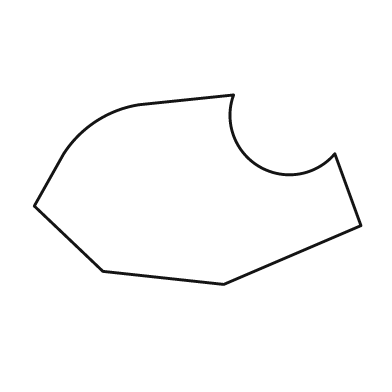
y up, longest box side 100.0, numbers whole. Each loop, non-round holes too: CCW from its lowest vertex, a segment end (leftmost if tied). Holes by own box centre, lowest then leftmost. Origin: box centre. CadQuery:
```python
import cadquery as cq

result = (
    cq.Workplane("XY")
    .moveTo(8.0, -29.0)
    .lineTo(50.0, -11.0)
    .lineTo(42.0, 11.0)
    .threePointArc((19.0, 7.0), (11.0, 29.0))
    .lineTo(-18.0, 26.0)
    .threePointArc((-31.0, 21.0), (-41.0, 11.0))
    .lineTo(-50.0, -5.0)
    .lineTo(-29.0, -25.0)
    .close()
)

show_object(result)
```